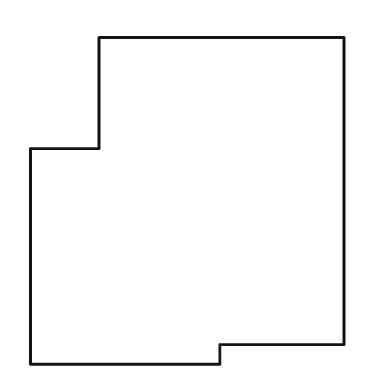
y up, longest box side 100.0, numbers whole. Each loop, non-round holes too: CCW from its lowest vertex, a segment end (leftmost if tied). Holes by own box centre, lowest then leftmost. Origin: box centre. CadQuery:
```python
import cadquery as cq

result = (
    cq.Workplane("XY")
    .moveTo(-48.0, -50.0)
    .lineTo(10.0, -50.0)
    .lineTo(10.0, -44.0)
    .lineTo(48.0, -44.0)
    .lineTo(48.0, 50.0)
    .lineTo(-27.0, 50.0)
    .lineTo(-27.0, 16.0)
    .lineTo(-48.0, 16.0)
    .close()
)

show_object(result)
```